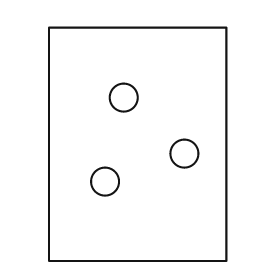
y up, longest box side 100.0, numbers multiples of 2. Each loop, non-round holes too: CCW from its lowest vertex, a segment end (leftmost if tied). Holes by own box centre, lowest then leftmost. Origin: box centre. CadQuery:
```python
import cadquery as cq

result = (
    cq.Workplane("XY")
    .moveTo(-38.0, -50.0)
    .lineTo(38.0, -50.0)
    .lineTo(38.0, 50.0)
    .lineTo(-38.0, 50.0)
    .close()
    .moveTo(-14.0, -16.0)
    .circle(6.0)
    .moveTo(20.0, -4.0)
    .circle(6.0)
    .moveTo(-6.0, 20.0)
    .circle(6.0)
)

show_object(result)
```